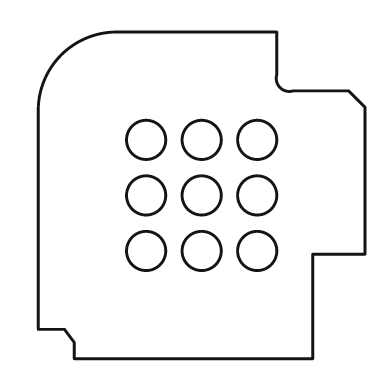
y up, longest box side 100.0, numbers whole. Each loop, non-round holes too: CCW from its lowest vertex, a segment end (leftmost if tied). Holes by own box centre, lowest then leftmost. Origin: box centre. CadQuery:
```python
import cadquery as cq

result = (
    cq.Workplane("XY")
    .moveTo(-39.0, -50.0)
    .lineTo(34.0, -50.0)
    .lineTo(34.0, -18.0)
    .lineTo(50.0, -18.0)
    .lineTo(50.0, 27.0)
    .lineTo(45.0, 32.0)
    .lineTo(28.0, 32.0)
    .threePointArc((24.0, 33.0), (23.0, 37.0))
    .lineTo(23.0, 50.0)
    .lineTo(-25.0, 50.0)
    .threePointArc((-43.0, 43.0), (-50.0, 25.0))
    .lineTo(-50.0, -41.0)
    .lineTo(-42.0, -41.0)
    .lineTo(-39.0, -45.0)
    .close()
    .moveTo(-17.0, -17.0)
    .circle(6.0)
    .moveTo(0.0, -17.0)
    .circle(6.0)
    .moveTo(17.0, -17.0)
    .circle(6.0)
    .moveTo(-17.0, 0.0)
    .circle(6.0)
    .moveTo(0.0, 0.0)
    .circle(6.0)
    .moveTo(17.0, 0.0)
    .circle(6.0)
    .moveTo(-17.0, 17.0)
    .circle(6.0)
    .moveTo(0.0, 17.0)
    .circle(6.0)
    .moveTo(17.0, 17.0)
    .circle(6.0)
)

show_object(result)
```